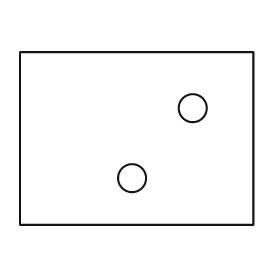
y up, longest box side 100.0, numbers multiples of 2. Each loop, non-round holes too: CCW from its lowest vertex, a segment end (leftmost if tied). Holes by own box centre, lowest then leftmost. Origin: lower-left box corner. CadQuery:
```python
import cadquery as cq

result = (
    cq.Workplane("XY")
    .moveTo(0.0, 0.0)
    .lineTo(100.0, 0.0)
    .lineTo(100.0, 74.0)
    .lineTo(0.0, 74.0)
    .close()
    .moveTo(48.0, 20.0)
    .circle(6.0)
    .moveTo(74.0, 50.0)
    .circle(6.0)
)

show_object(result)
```